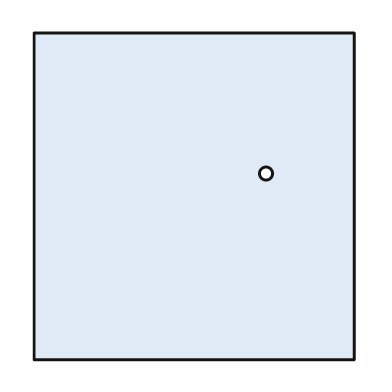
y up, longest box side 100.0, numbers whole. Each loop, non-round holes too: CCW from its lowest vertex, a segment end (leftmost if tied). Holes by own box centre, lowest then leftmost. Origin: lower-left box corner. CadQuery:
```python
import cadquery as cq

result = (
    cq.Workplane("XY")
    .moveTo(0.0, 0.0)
    .lineTo(98.0, 0.0)
    .lineTo(98.0, 100.0)
    .lineTo(0.0, 100.0)
    .close()
    .moveTo(71.0, 57.0)
    .circle(2.0)
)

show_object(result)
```